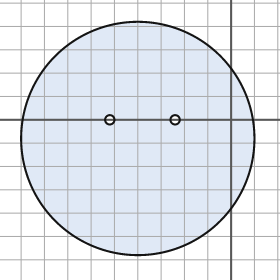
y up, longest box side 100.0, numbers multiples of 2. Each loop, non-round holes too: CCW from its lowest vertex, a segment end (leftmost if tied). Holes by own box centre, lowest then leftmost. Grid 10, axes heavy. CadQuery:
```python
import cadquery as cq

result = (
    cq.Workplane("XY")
    .moveTo(-40.0, -8.0)
    .circle(50.0)
    .moveTo(-52.0, 0.0)
    .circle(2.0)
    .moveTo(-24.0, 0.0)
    .circle(2.0)
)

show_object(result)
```